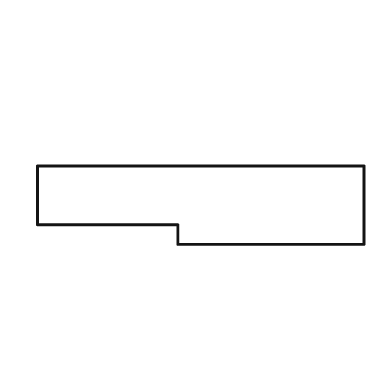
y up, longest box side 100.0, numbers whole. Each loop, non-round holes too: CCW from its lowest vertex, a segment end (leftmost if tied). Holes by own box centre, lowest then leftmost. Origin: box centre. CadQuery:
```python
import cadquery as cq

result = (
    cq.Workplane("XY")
    .moveTo(-7.0, -12.0)
    .lineTo(50.0, -12.0)
    .lineTo(50.0, 12.0)
    .lineTo(-50.0, 12.0)
    .lineTo(-50.0, -6.0)
    .lineTo(-7.0, -6.0)
    .close()
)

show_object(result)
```